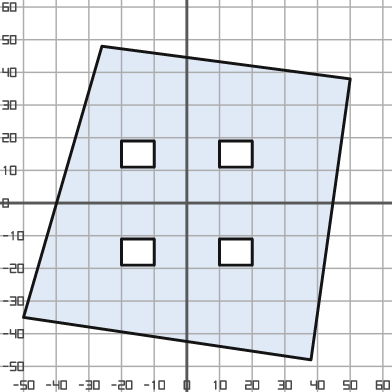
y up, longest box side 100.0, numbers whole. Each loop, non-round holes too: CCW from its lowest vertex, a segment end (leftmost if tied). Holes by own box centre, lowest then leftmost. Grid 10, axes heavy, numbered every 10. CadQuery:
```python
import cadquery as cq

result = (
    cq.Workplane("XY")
    .moveTo(38.0, -48.0)
    .lineTo(50.0, 38.0)
    .lineTo(-26.0, 48.0)
    .lineTo(-50.0, -35.0)
    .close()
    .moveTo(-20.0, -19.0)
    .lineTo(-10.0, -19.0)
    .lineTo(-10.0, -11.0)
    .lineTo(-20.0, -11.0)
    .close()
    .moveTo(10.0, -19.0)
    .lineTo(20.0, -19.0)
    .lineTo(20.0, -11.0)
    .lineTo(10.0, -11.0)
    .close()
    .moveTo(-20.0, 11.0)
    .lineTo(-10.0, 11.0)
    .lineTo(-10.0, 19.0)
    .lineTo(-20.0, 19.0)
    .close()
    .moveTo(10.0, 11.0)
    .lineTo(20.0, 11.0)
    .lineTo(20.0, 19.0)
    .lineTo(10.0, 19.0)
    .close()
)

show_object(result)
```